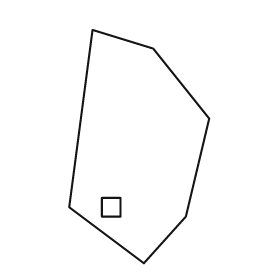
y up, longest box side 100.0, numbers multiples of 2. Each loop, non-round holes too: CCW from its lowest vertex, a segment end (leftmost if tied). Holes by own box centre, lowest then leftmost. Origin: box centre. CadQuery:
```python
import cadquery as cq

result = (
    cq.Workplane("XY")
    .moveTo(2.0, -50.0)
    .lineTo(20.0, -30.0)
    .lineTo(30.0, 12.0)
    .lineTo(6.0, 42.0)
    .lineTo(-20.0, 50.0)
    .lineTo(-30.0, -26.0)
    .close()
    .moveTo(-16.0, -30.0)
    .lineTo(-8.0, -30.0)
    .lineTo(-8.0, -22.0)
    .lineTo(-16.0, -22.0)
    .close()
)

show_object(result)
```